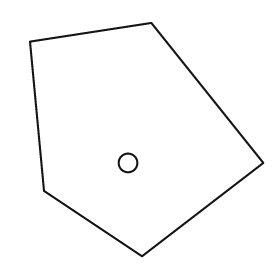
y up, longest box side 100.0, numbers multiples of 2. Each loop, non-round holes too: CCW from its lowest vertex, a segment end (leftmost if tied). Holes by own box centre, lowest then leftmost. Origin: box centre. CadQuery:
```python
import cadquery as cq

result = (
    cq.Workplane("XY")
    .moveTo(-2.0, -50.0)
    .lineTo(50.0, -10.0)
    .lineTo(2.0, 50.0)
    .lineTo(-50.0, 42.0)
    .lineTo(-44.0, -22.0)
    .close()
    .moveTo(-8.0, -10.0)
    .circle(4.0)
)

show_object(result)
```